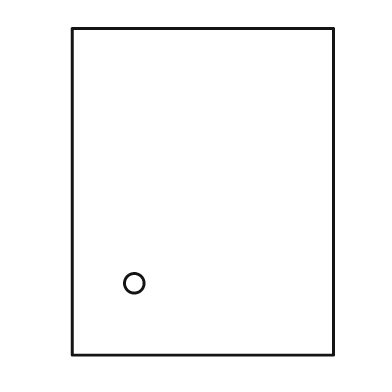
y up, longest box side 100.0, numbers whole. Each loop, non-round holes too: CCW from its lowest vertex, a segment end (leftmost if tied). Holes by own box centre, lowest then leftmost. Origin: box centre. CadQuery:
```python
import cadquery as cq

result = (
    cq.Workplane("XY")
    .moveTo(-40.0, -50.0)
    .lineTo(40.0, -50.0)
    .lineTo(40.0, 50.0)
    .lineTo(-40.0, 50.0)
    .close()
    .moveTo(-21.0, -28.0)
    .circle(3.0)
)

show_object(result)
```